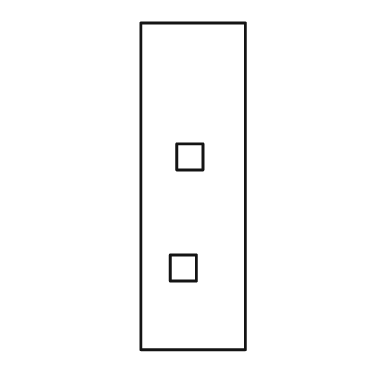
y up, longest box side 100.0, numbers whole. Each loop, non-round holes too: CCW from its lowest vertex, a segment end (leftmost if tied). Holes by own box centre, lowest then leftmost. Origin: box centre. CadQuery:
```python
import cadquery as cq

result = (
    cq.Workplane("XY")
    .moveTo(-16.0, -50.0)
    .lineTo(16.0, -50.0)
    .lineTo(16.0, 50.0)
    .lineTo(-16.0, 50.0)
    .close()
    .moveTo(-7.0, -29.0)
    .lineTo(1.0, -29.0)
    .lineTo(1.0, -21.0)
    .lineTo(-7.0, -21.0)
    .close()
    .moveTo(-5.0, 5.0)
    .lineTo(3.0, 5.0)
    .lineTo(3.0, 13.0)
    .lineTo(-5.0, 13.0)
    .close()
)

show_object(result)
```